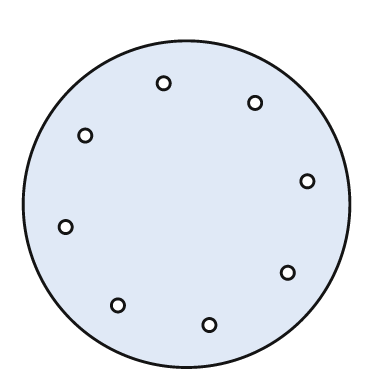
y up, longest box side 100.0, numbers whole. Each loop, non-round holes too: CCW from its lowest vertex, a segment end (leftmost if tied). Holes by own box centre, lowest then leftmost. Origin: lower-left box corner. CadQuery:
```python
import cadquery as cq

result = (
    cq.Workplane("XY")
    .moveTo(50.0, 50.0)
    .circle(50.0)
    .moveTo(57.0, 13.0)
    .circle(2.0)
    .moveTo(29.0, 19.0)
    .circle(2.0)
    .moveTo(81.0, 29.0)
    .circle(2.0)
    .moveTo(13.0, 43.0)
    .circle(2.0)
    .moveTo(87.0, 57.0)
    .circle(2.0)
    .moveTo(19.0, 71.0)
    .circle(2.0)
    .moveTo(71.0, 81.0)
    .circle(2.0)
    .moveTo(43.0, 87.0)
    .circle(2.0)
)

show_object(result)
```